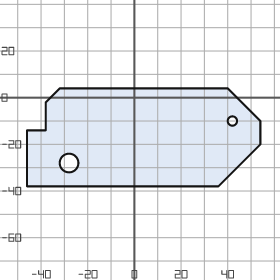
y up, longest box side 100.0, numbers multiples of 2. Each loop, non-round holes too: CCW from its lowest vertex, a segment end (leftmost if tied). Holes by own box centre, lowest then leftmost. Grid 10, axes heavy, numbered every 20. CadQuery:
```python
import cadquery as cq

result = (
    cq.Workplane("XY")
    .moveTo(-46.0, -38.0)
    .lineTo(36.0, -38.0)
    .lineTo(54.0, -20.0)
    .lineTo(54.0, -10.0)
    .lineTo(40.0, 4.0)
    .lineTo(-32.0, 4.0)
    .lineTo(-38.0, -2.0)
    .lineTo(-38.0, -14.0)
    .lineTo(-46.0, -14.0)
    .close()
    .moveTo(-28.0, -28.0)
    .circle(4.0)
    .moveTo(42.0, -10.0)
    .circle(2.0)
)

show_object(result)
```